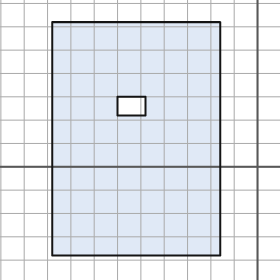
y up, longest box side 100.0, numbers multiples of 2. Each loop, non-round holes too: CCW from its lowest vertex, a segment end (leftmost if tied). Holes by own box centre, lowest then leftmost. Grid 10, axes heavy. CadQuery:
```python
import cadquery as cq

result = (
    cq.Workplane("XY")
    .moveTo(-88.0, -38.0)
    .lineTo(-16.0, -38.0)
    .lineTo(-16.0, 62.0)
    .lineTo(-88.0, 62.0)
    .close()
    .moveTo(-60.0, 22.0)
    .lineTo(-48.0, 22.0)
    .lineTo(-48.0, 30.0)
    .lineTo(-60.0, 30.0)
    .close()
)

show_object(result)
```